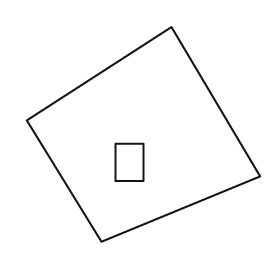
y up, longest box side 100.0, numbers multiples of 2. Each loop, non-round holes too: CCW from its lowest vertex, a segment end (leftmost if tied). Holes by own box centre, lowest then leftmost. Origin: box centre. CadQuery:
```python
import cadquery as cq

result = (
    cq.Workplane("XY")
    .moveTo(-18.0, -46.0)
    .lineTo(50.0, -18.0)
    .lineTo(12.0, 46.0)
    .lineTo(-50.0, 6.0)
    .close()
    .moveTo(-12.0, -20.0)
    .lineTo(0.0, -20.0)
    .lineTo(0.0, -4.0)
    .lineTo(-12.0, -4.0)
    .close()
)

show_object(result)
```